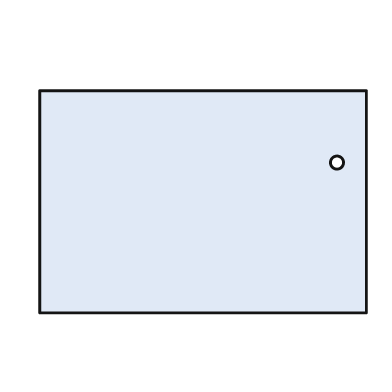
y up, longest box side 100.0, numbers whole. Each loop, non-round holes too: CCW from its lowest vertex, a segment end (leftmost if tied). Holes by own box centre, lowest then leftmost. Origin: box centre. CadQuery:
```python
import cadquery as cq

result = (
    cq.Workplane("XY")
    .moveTo(-50.0, -34.0)
    .lineTo(50.0, -34.0)
    .lineTo(50.0, 34.0)
    .lineTo(-50.0, 34.0)
    .close()
    .moveTo(41.0, 12.0)
    .circle(2.0)
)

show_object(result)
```